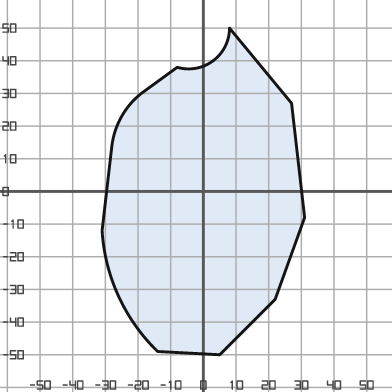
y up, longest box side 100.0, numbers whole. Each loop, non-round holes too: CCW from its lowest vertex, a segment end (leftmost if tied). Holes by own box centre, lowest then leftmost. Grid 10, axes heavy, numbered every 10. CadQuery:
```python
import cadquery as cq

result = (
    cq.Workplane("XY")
    .moveTo(5.0, -50.0)
    .lineTo(22.0, -33.0)
    .lineTo(31.0, -8.0)
    .lineTo(27.0, 27.0)
    .lineTo(8.0, 50.0)
    .threePointArc((3.0, 40.0), (-8.0, 38.0))
    .lineTo(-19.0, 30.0)
    .threePointArc((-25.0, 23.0), (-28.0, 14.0))
    .lineTo(-31.0, -12.0)
    .threePointArc((-26.0, -32.0), (-14.0, -49.0))
    .close()
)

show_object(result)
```